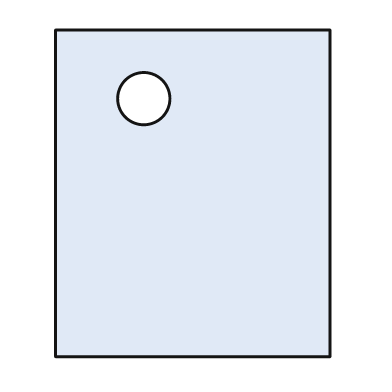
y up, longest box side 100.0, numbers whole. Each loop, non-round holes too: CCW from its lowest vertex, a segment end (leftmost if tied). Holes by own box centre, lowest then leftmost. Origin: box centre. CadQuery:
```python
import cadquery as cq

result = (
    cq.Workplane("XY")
    .moveTo(-42.0, -50.0)
    .lineTo(42.0, -50.0)
    .lineTo(42.0, 50.0)
    .lineTo(-42.0, 50.0)
    .close()
    .moveTo(-15.0, 29.0)
    .circle(8.0)
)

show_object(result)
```